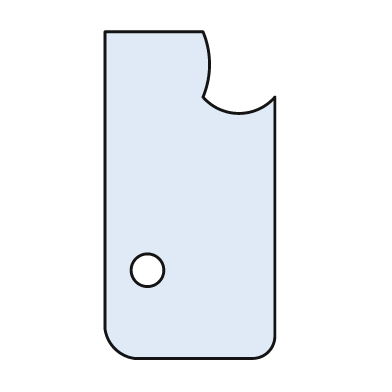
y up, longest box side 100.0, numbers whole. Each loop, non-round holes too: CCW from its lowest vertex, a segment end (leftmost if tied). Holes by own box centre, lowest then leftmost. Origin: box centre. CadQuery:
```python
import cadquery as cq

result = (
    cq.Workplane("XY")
    .moveTo(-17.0, -50.0)
    .lineTo(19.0, -50.0)
    .threePointArc((24.0, -48.0), (26.0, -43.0))
    .lineTo(26.0, 30.0)
    .threePointArc((15.0, 25.0), (4.0, 30.0))
    .threePointArc((6.0, 40.0), (4.0, 50.0))
    .lineTo(-26.0, 50.0)
    .lineTo(-26.0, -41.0)
    .threePointArc((-23.0, -47.0), (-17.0, -50.0))
    .close()
    .moveTo(-13.0, -23.0)
    .circle(5.0)
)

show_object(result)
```